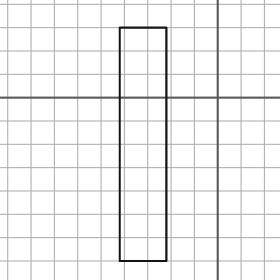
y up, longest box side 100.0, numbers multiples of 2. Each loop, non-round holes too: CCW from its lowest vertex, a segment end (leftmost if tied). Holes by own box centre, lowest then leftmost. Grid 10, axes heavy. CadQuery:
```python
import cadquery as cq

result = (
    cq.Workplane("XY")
    .moveTo(-42.0, -70.0)
    .lineTo(-22.0, -70.0)
    .lineTo(-22.0, 30.0)
    .lineTo(-42.0, 30.0)
    .close()
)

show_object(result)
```